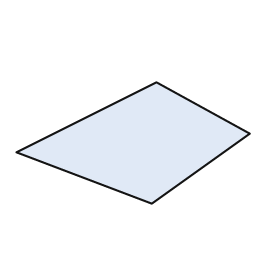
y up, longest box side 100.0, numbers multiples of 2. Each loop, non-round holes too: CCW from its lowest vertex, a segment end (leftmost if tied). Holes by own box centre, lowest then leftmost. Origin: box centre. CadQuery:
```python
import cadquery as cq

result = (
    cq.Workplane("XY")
    .moveTo(8.0, -26.0)
    .lineTo(50.0, 4.0)
    .lineTo(10.0, 26.0)
    .lineTo(-50.0, -4.0)
    .close()
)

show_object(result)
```